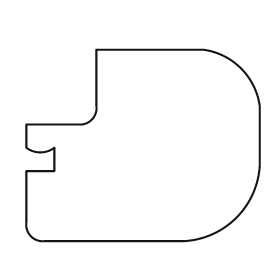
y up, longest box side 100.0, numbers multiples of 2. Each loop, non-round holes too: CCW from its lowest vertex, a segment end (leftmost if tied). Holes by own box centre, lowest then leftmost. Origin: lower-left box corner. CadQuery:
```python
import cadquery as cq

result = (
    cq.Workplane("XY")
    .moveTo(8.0, 0.0)
    .lineTo(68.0, 0.0)
    .threePointArc((90.0, 10.0), (100.0, 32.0))
    .lineTo(100.0, 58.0)
    .threePointArc((92.0, 74.0), (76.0, 82.0))
    .lineTo(30.0, 82.0)
    .lineTo(30.0, 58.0)
    .threePointArc((28.0, 52.0), (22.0, 50.0))
    .lineTo(0.0, 50.0)
    .lineTo(0.0, 40.0)
    .threePointArc((6.0, 38.0), (12.0, 40.0))
    .lineTo(12.0, 30.0)
    .lineTo(0.0, 30.0)
    .lineTo(0.0, 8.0)
    .threePointArc((2.0, 2.0), (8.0, 0.0))
    .close()
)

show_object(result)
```